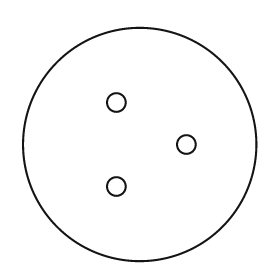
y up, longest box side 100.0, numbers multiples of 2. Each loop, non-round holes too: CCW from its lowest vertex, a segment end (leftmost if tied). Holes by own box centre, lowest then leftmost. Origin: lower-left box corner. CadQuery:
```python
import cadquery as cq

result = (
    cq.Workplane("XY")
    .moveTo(50.0, 50.0)
    .circle(50.0)
    .moveTo(40.0, 32.0)
    .circle(4.0)
    .moveTo(70.0, 50.0)
    .circle(4.0)
    .moveTo(40.0, 68.0)
    .circle(4.0)
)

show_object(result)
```